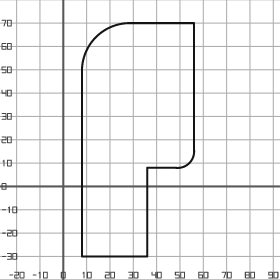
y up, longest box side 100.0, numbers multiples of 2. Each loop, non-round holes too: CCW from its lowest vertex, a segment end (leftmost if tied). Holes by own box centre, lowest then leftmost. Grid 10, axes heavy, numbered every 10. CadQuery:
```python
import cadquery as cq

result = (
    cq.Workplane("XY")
    .moveTo(8.0, -30.0)
    .lineTo(36.0, -30.0)
    .lineTo(36.0, 8.0)
    .lineTo(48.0, 8.0)
    .threePointArc((54.0, 10.0), (56.0, 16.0))
    .lineTo(56.0, 70.0)
    .lineTo(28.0, 70.0)
    .threePointArc((14.0, 64.0), (8.0, 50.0))
    .close()
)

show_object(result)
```